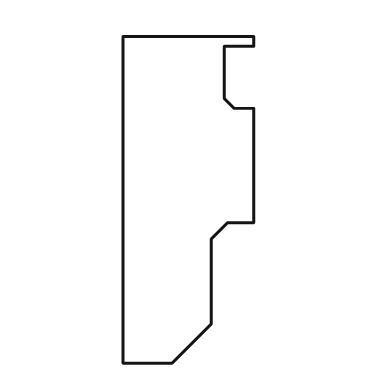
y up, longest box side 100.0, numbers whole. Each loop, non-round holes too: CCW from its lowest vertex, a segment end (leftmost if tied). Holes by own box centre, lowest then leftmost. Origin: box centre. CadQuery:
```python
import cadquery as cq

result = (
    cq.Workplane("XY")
    .moveTo(-20.0, -50.0)
    .lineTo(-5.0, -50.0)
    .lineTo(7.0, -38.0)
    .lineTo(7.0, -12.0)
    .lineTo(12.0, -7.0)
    .lineTo(20.0, -7.0)
    .lineTo(20.0, 28.0)
    .lineTo(14.0, 28.0)
    .lineTo(11.0, 31.0)
    .lineTo(11.0, 47.0)
    .lineTo(20.0, 47.0)
    .lineTo(20.0, 50.0)
    .lineTo(-20.0, 50.0)
    .close()
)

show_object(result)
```